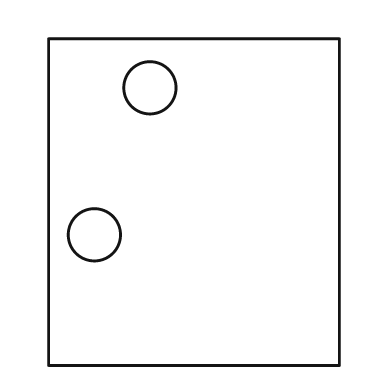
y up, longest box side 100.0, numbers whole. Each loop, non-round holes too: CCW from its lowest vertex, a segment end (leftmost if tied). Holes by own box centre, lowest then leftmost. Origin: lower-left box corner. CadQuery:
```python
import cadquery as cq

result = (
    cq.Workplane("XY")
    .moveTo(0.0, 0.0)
    .lineTo(89.0, 0.0)
    .lineTo(89.0, 100.0)
    .lineTo(0.0, 100.0)
    .close()
    .moveTo(14.0, 40.0)
    .circle(8.0)
    .moveTo(31.0, 85.0)
    .circle(8.0)
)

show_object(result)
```